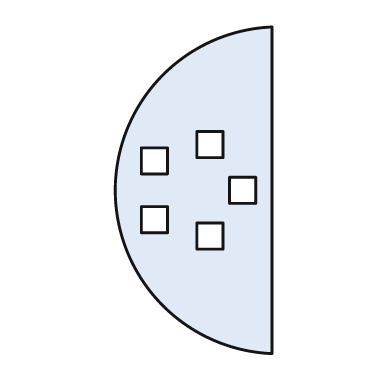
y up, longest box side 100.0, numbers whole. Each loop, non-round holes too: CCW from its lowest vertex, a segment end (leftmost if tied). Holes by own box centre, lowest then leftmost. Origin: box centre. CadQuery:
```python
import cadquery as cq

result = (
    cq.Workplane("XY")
    .moveTo(24.0, -50.0)
    .lineTo(24.0, 50.0)
    .threePointArc((-24.0, 0.0), (24.0, -50.0))
    .close()
    .moveTo(1.0, -18.0)
    .lineTo(9.0, -18.0)
    .lineTo(9.0, -10.0)
    .lineTo(1.0, -10.0)
    .close()
    .moveTo(-16.0, -13.0)
    .lineTo(-8.0, -13.0)
    .lineTo(-8.0, -5.0)
    .lineTo(-16.0, -5.0)
    .close()
    .moveTo(11.0, -4.0)
    .lineTo(19.0, -4.0)
    .lineTo(19.0, 4.0)
    .lineTo(11.0, 4.0)
    .close()
    .moveTo(-16.0, 5.0)
    .lineTo(-8.0, 5.0)
    .lineTo(-8.0, 13.0)
    .lineTo(-16.0, 13.0)
    .close()
    .moveTo(1.0, 10.0)
    .lineTo(9.0, 10.0)
    .lineTo(9.0, 18.0)
    .lineTo(1.0, 18.0)
    .close()
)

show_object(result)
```